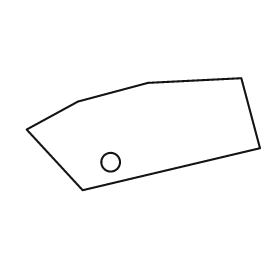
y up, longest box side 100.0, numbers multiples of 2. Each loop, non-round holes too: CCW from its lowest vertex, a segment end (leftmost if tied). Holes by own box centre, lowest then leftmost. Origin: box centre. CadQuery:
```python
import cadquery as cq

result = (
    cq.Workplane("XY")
    .moveTo(-26.0, -24.0)
    .lineTo(50.0, -6.0)
    .lineTo(42.0, 24.0)
    .lineTo(2.0, 22.0)
    .lineTo(-28.0, 14.0)
    .lineTo(-50.0, 2.0)
    .close()
    .moveTo(-14.0, -12.0)
    .circle(4.0)
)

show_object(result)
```